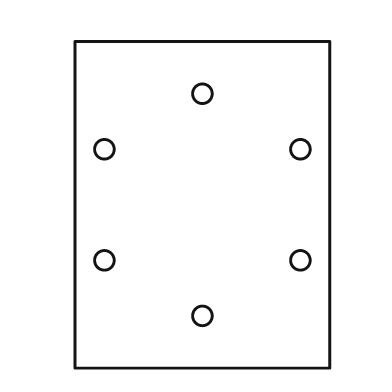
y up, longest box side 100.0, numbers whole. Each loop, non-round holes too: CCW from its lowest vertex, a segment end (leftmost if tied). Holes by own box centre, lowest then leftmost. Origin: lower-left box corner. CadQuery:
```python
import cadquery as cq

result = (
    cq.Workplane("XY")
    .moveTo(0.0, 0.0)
    .lineTo(78.0, 0.0)
    .lineTo(78.0, 100.0)
    .lineTo(0.0, 100.0)
    .close()
    .moveTo(39.0, 16.0)
    .circle(3.0)
    .moveTo(9.0, 33.0)
    .circle(3.0)
    .moveTo(69.0, 33.0)
    .circle(3.0)
    .moveTo(9.0, 67.0)
    .circle(3.0)
    .moveTo(69.0, 67.0)
    .circle(3.0)
    .moveTo(39.0, 84.0)
    .circle(3.0)
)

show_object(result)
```